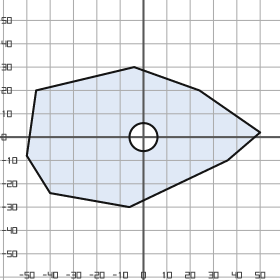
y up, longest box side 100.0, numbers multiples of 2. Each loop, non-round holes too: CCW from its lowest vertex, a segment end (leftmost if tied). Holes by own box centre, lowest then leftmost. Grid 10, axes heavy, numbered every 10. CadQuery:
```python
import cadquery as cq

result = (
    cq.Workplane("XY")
    .moveTo(-6.0, -30.0)
    .lineTo(36.0, -10.0)
    .lineTo(50.0, 2.0)
    .lineTo(24.0, 20.0)
    .lineTo(-4.0, 30.0)
    .lineTo(-46.0, 20.0)
    .lineTo(-50.0, -8.0)
    .lineTo(-40.0, -24.0)
    .close()
    .moveTo(0.0, 0.0)
    .circle(6.0)
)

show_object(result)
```